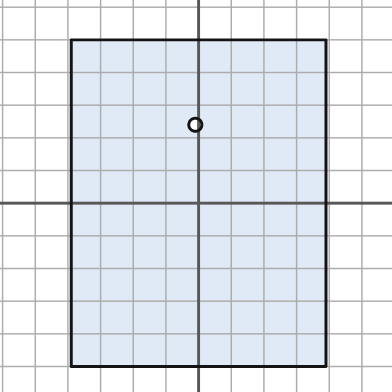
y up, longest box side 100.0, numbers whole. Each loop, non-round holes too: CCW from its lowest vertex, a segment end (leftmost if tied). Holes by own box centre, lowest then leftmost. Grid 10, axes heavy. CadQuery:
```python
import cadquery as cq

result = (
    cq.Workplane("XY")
    .moveTo(-39.0, -50.0)
    .lineTo(39.0, -50.0)
    .lineTo(39.0, 50.0)
    .lineTo(-39.0, 50.0)
    .close()
    .moveTo(-1.0, 24.0)
    .circle(2.0)
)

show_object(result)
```